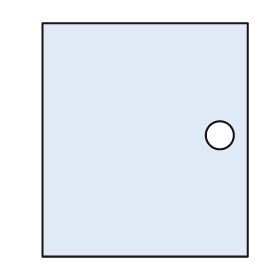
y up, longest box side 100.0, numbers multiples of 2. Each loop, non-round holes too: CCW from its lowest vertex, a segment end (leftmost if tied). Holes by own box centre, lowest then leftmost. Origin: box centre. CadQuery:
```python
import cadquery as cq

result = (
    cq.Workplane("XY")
    .moveTo(-44.0, -50.0)
    .lineTo(44.0, -50.0)
    .lineTo(44.0, 50.0)
    .lineTo(-44.0, 50.0)
    .close()
    .moveTo(32.0, 2.0)
    .circle(6.0)
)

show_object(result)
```